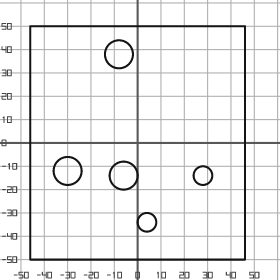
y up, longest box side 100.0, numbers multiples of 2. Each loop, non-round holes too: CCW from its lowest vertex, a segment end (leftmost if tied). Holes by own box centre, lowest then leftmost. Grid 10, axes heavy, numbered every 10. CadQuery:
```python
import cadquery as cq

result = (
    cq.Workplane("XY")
    .moveTo(-46.0, -50.0)
    .lineTo(46.0, -50.0)
    .lineTo(46.0, 50.0)
    .lineTo(-46.0, 50.0)
    .close()
    .moveTo(4.0, -34.0)
    .circle(4.0)
    .moveTo(-6.0, -14.0)
    .circle(6.0)
    .moveTo(28.0, -14.0)
    .circle(4.0)
    .moveTo(-30.0, -12.0)
    .circle(6.0)
    .moveTo(-8.0, 38.0)
    .circle(6.0)
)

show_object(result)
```